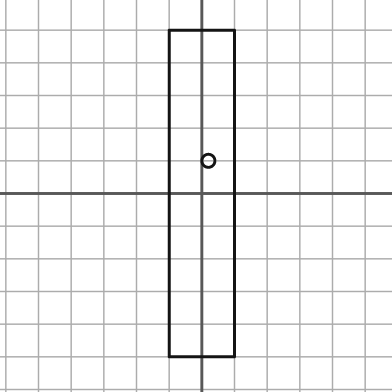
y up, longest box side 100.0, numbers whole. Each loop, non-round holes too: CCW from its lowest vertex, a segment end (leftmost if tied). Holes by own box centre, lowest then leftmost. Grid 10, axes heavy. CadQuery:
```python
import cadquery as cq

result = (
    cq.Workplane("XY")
    .moveTo(-10.0, -50.0)
    .lineTo(10.0, -50.0)
    .lineTo(10.0, 50.0)
    .lineTo(-10.0, 50.0)
    .close()
    .moveTo(2.0, 10.0)
    .circle(2.0)
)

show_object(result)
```